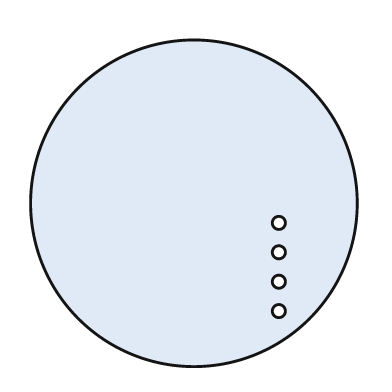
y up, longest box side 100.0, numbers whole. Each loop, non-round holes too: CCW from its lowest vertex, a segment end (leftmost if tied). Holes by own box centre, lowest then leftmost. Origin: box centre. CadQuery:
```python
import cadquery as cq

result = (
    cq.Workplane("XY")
    .moveTo(0.0, 0.0)
    .circle(50.0)
    .moveTo(26.0, -33.0)
    .circle(2.0)
    .moveTo(26.0, -24.0)
    .circle(2.0)
    .moveTo(26.0, -15.0)
    .circle(2.0)
    .moveTo(26.0, -6.0)
    .circle(2.0)
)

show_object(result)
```